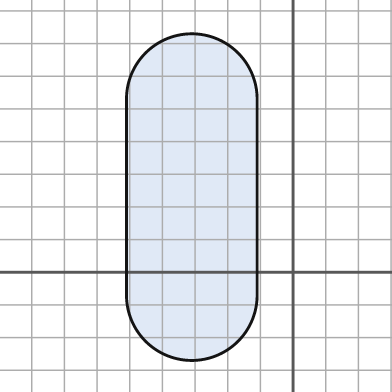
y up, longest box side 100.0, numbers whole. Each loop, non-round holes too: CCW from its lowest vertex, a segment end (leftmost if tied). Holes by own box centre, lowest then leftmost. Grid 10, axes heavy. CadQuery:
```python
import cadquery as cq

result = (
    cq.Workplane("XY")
    .moveTo(-51.0, -7.0)
    .threePointArc((-31.0, -27.0), (-11.0, -7.0))
    .lineTo(-11.0, 53.0)
    .threePointArc((-31.0, 73.0), (-51.0, 53.0))
    .close()
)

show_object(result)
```